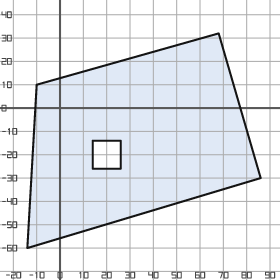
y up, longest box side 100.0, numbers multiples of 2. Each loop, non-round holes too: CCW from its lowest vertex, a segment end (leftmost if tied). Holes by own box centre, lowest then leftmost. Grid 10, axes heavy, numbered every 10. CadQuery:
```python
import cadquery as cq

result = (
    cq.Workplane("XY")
    .moveTo(-14.0, -60.0)
    .lineTo(86.0, -30.0)
    .lineTo(68.0, 32.0)
    .lineTo(-10.0, 10.0)
    .close()
    .moveTo(14.0, -26.0)
    .lineTo(26.0, -26.0)
    .lineTo(26.0, -14.0)
    .lineTo(14.0, -14.0)
    .close()
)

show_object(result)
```